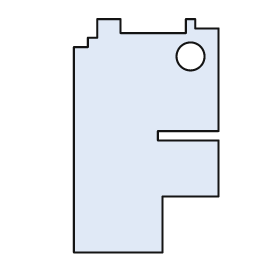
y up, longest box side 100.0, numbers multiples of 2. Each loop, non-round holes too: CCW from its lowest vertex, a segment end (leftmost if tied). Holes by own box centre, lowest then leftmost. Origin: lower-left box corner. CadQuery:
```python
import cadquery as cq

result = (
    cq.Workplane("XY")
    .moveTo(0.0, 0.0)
    .lineTo(38.0, 0.0)
    .lineTo(38.0, 24.0)
    .lineTo(62.0, 24.0)
    .lineTo(62.0, 48.0)
    .lineTo(36.0, 48.0)
    .lineTo(36.0, 52.0)
    .lineTo(62.0, 52.0)
    .lineTo(62.0, 96.0)
    .lineTo(52.0, 96.0)
    .lineTo(52.0, 100.0)
    .lineTo(48.0, 100.0)
    .lineTo(48.0, 94.0)
    .lineTo(20.0, 94.0)
    .lineTo(20.0, 100.0)
    .lineTo(10.0, 100.0)
    .lineTo(10.0, 92.0)
    .lineTo(6.0, 92.0)
    .lineTo(6.0, 88.0)
    .lineTo(0.0, 88.0)
    .close()
    .moveTo(50.0, 84.0)
    .circle(6.0)
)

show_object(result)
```